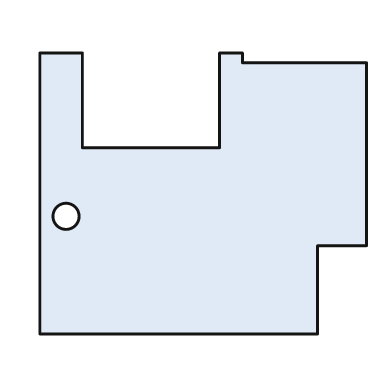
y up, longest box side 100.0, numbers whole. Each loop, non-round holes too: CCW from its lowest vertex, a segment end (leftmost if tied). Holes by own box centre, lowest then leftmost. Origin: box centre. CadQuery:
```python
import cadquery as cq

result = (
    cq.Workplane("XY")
    .moveTo(-50.0, -43.0)
    .lineTo(35.0, -43.0)
    .lineTo(35.0, -16.0)
    .lineTo(50.0, -16.0)
    .lineTo(50.0, 40.0)
    .lineTo(12.0, 40.0)
    .lineTo(12.0, 43.0)
    .lineTo(5.0, 43.0)
    .lineTo(5.0, 14.0)
    .lineTo(-37.0, 14.0)
    .lineTo(-37.0, 43.0)
    .lineTo(-50.0, 43.0)
    .close()
    .moveTo(-42.0, -7.0)
    .circle(4.0)
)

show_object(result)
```